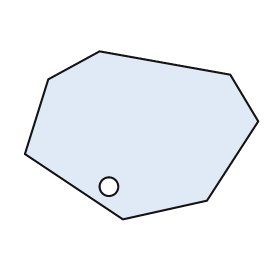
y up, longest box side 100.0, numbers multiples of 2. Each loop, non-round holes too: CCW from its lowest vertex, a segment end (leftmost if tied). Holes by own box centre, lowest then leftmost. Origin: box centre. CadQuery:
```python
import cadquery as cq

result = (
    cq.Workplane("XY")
    .moveTo(-8.0, -36.0)
    .lineTo(28.0, -28.0)
    .lineTo(50.0, 6.0)
    .lineTo(38.0, 26.0)
    .lineTo(-18.0, 36.0)
    .lineTo(-40.0, 24.0)
    .lineTo(-50.0, -8.0)
    .close()
    .moveTo(-14.0, -22.0)
    .circle(4.0)
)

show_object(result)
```